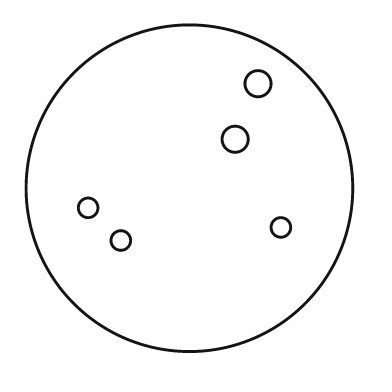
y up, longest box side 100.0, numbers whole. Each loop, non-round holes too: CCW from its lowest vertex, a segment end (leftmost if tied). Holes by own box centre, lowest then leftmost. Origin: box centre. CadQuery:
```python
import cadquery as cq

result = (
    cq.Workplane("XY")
    .moveTo(0.0, 0.0)
    .circle(50.0)
    .moveTo(-21.0, -16.0)
    .circle(3.0)
    .moveTo(28.0, -12.0)
    .circle(3.0)
    .moveTo(-31.0, -6.0)
    .circle(3.0)
    .moveTo(14.0, 15.0)
    .circle(4.0)
    .moveTo(21.0, 32.0)
    .circle(4.0)
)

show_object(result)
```